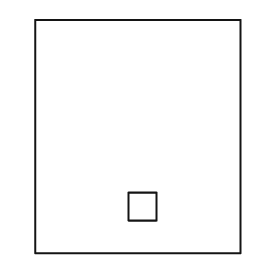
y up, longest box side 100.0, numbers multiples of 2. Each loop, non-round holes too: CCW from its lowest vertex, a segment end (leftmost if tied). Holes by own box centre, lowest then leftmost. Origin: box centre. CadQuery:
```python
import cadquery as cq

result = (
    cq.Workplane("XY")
    .moveTo(-44.0, -50.0)
    .lineTo(44.0, -50.0)
    .lineTo(44.0, 50.0)
    .lineTo(-44.0, 50.0)
    .close()
    .moveTo(-4.0, -36.0)
    .lineTo(8.0, -36.0)
    .lineTo(8.0, -24.0)
    .lineTo(-4.0, -24.0)
    .close()
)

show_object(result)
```